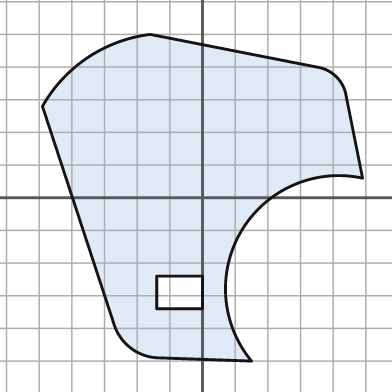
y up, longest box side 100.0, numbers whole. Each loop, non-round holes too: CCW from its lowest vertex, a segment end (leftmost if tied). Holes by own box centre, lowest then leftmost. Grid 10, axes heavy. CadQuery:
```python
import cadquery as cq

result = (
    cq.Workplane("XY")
    .moveTo(15.0, -50.0)
    .threePointArc((12.0, -10.0), (49.0, 6.0))
    .lineTo(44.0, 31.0)
    .threePointArc((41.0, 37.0), (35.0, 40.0))
    .lineTo(-16.0, 50.0)
    .threePointArc((-35.0, 43.0), (-49.0, 28.0))
    .lineTo(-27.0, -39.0)
    .threePointArc((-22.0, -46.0), (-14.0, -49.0))
    .close()
    .moveTo(-14.0, -34.0)
    .lineTo(0.0, -34.0)
    .lineTo(0.0, -24.0)
    .lineTo(-14.0, -24.0)
    .close()
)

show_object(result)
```